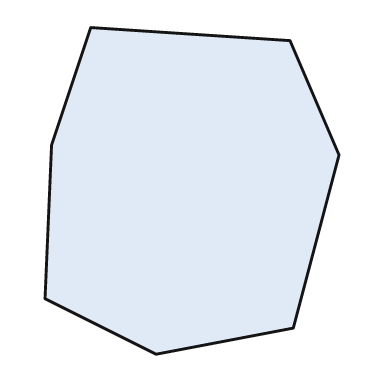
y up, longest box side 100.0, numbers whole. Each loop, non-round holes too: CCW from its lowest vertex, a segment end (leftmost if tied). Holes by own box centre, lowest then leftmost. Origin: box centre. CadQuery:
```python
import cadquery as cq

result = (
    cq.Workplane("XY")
    .moveTo(-11.0, -50.0)
    .lineTo(31.0, -42.0)
    .lineTo(45.0, 11.0)
    .lineTo(30.0, 46.0)
    .lineTo(-31.0, 50.0)
    .lineTo(-43.0, 14.0)
    .lineTo(-45.0, -33.0)
    .close()
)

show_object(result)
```